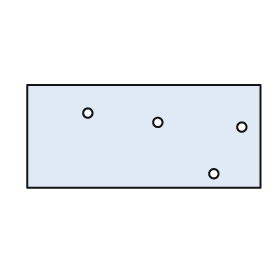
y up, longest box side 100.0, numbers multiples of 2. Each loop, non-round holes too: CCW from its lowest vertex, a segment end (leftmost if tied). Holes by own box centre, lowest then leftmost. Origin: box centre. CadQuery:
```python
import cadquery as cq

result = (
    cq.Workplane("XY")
    .moveTo(-50.0, -22.0)
    .lineTo(50.0, -22.0)
    .lineTo(50.0, 22.0)
    .lineTo(-50.0, 22.0)
    .close()
    .moveTo(30.0, -16.0)
    .circle(2.0)
    .moveTo(42.0, 4.0)
    .circle(2.0)
    .moveTo(6.0, 6.0)
    .circle(2.0)
    .moveTo(-24.0, 10.0)
    .circle(2.0)
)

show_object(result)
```